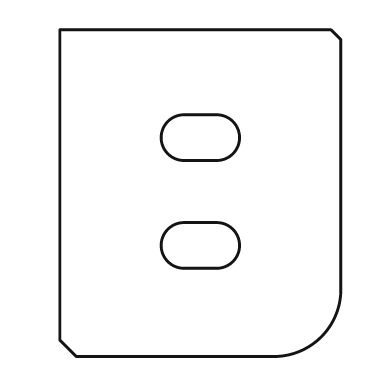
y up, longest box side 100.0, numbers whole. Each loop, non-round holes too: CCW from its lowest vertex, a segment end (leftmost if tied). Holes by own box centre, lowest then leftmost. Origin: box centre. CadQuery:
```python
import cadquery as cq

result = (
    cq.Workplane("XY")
    .moveTo(-38.0, -50.0)
    .lineTo(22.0, -50.0)
    .threePointArc((37.0, -44.0), (43.0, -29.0))
    .lineTo(43.0, 47.0)
    .lineTo(40.0, 50.0)
    .lineTo(-43.0, 50.0)
    .lineTo(-43.0, -45.0)
    .close()
    .moveTo(-5.0, -23.0)
    .lineTo(5.0, -23.0)
    .threePointArc((12.0, -16.0), (5.0, -9.0))
    .lineTo(-5.0, -9.0)
    .threePointArc((-12.0, -16.0), (-5.0, -23.0))
    .close()
    .moveTo(-5.0, 10.0)
    .lineTo(5.0, 10.0)
    .threePointArc((12.0, 17.0), (5.0, 24.0))
    .lineTo(-5.0, 24.0)
    .threePointArc((-12.0, 17.0), (-5.0, 10.0))
    .close()
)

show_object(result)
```